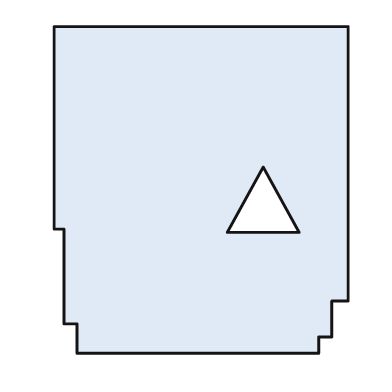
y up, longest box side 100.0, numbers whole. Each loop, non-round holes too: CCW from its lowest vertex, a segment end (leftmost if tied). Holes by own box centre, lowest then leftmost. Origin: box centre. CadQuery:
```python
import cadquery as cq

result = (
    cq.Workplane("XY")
    .moveTo(-38.0, -50.0)
    .lineTo(36.0, -50.0)
    .lineTo(36.0, -45.0)
    .lineTo(40.0, -45.0)
    .lineTo(40.0, -34.0)
    .lineTo(45.0, -34.0)
    .lineTo(45.0, 50.0)
    .lineTo(-45.0, 50.0)
    .lineTo(-45.0, -12.0)
    .lineTo(-42.0, -12.0)
    .lineTo(-42.0, -41.0)
    .lineTo(-38.0, -41.0)
    .close()
    .moveTo(8.0, -13.0)
    .lineTo(30.0, -13.0)
    .lineTo(19.0, 7.0)
    .close()
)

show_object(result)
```